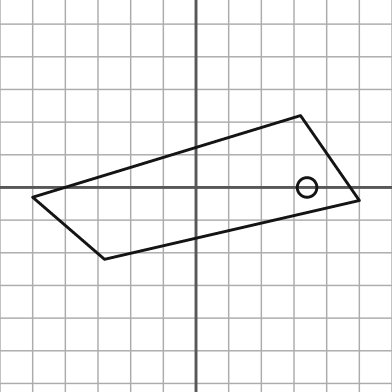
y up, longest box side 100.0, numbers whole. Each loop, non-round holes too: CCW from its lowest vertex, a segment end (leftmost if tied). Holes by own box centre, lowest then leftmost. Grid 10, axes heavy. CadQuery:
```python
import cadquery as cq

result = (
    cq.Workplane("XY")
    .moveTo(-28.0, -22.0)
    .lineTo(50.0, -4.0)
    .lineTo(32.0, 22.0)
    .lineTo(-50.0, -3.0)
    .close()
    .moveTo(34.0, 0.0)
    .circle(3.0)
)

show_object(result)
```